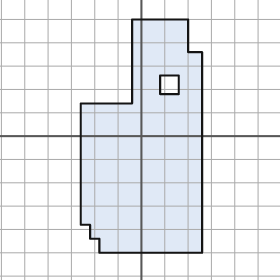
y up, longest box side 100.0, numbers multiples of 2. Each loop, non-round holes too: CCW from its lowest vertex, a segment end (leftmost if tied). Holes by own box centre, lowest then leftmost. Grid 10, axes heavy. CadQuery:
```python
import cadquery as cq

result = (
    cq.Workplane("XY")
    .moveTo(-18.0, -50.0)
    .lineTo(26.0, -50.0)
    .lineTo(26.0, 36.0)
    .lineTo(20.0, 36.0)
    .lineTo(20.0, 50.0)
    .lineTo(-4.0, 50.0)
    .lineTo(-4.0, 14.0)
    .lineTo(-26.0, 14.0)
    .lineTo(-26.0, -38.0)
    .lineTo(-22.0, -38.0)
    .lineTo(-22.0, -44.0)
    .lineTo(-18.0, -44.0)
    .close()
    .moveTo(8.0, 18.0)
    .lineTo(16.0, 18.0)
    .lineTo(16.0, 26.0)
    .lineTo(8.0, 26.0)
    .close()
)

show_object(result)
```